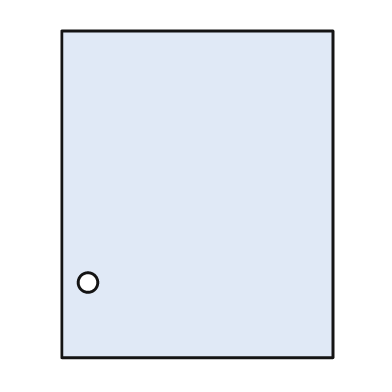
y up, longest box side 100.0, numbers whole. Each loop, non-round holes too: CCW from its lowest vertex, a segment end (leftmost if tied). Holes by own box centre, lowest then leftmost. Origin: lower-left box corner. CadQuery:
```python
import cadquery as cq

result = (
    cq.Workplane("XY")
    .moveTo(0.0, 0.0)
    .lineTo(83.0, 0.0)
    .lineTo(83.0, 100.0)
    .lineTo(0.0, 100.0)
    .close()
    .moveTo(8.0, 23.0)
    .circle(3.0)
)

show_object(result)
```